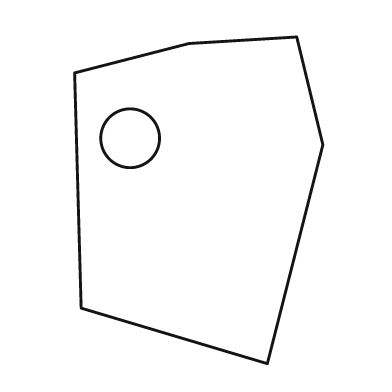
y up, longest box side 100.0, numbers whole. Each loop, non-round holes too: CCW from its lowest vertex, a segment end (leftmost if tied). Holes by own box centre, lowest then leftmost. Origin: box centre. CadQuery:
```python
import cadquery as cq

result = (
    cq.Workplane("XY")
    .moveTo(21.0, -50.0)
    .lineTo(38.0, 17.0)
    .lineTo(30.0, 50.0)
    .lineTo(-3.0, 48.0)
    .lineTo(-38.0, 39.0)
    .lineTo(-36.0, -33.0)
    .close()
    .moveTo(-21.0, 19.0)
    .circle(9.0)
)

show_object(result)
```